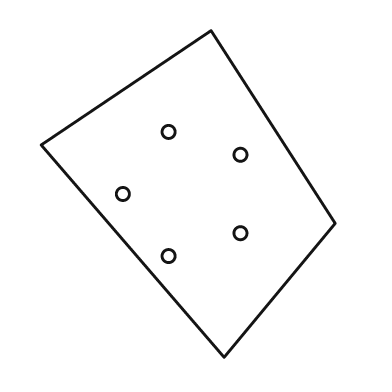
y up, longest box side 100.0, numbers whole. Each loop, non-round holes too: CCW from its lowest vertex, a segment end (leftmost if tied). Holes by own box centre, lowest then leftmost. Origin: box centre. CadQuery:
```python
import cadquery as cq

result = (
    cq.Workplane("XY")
    .moveTo(11.0, -50.0)
    .lineTo(45.0, -9.0)
    .lineTo(7.0, 50.0)
    .lineTo(-45.0, 15.0)
    .close()
    .moveTo(-6.0, -19.0)
    .circle(2.0)
    .moveTo(16.0, -12.0)
    .circle(2.0)
    .moveTo(-20.0, 0.0)
    .circle(2.0)
    .moveTo(16.0, 12.0)
    .circle(2.0)
    .moveTo(-6.0, 19.0)
    .circle(2.0)
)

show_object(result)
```